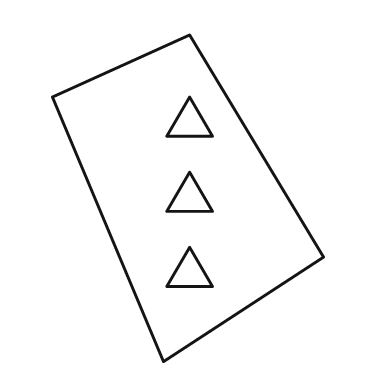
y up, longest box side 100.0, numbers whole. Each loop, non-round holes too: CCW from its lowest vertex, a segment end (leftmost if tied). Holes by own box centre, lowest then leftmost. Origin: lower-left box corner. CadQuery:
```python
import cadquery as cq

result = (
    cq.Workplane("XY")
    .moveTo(34.0, 0.0)
    .lineTo(83.0, 32.0)
    .lineTo(42.0, 100.0)
    .lineTo(0.0, 81.0)
    .close()
    .moveTo(35.0, 23.0)
    .lineTo(49.0, 23.0)
    .lineTo(42.0, 35.0)
    .close()
    .moveTo(35.0, 46.0)
    .lineTo(49.0, 46.0)
    .lineTo(42.0, 58.0)
    .close()
    .moveTo(35.0, 69.0)
    .lineTo(49.0, 69.0)
    .lineTo(42.0, 81.0)
    .close()
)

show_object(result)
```